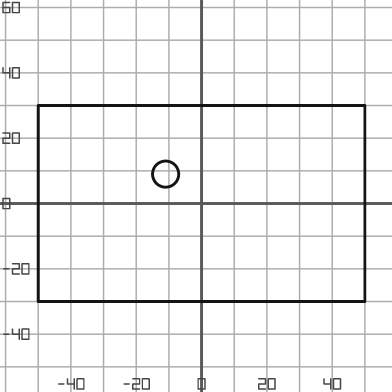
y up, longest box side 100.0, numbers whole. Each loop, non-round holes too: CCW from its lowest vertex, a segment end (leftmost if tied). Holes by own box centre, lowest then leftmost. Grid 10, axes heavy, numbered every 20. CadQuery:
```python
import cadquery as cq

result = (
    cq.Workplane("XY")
    .moveTo(-50.0, -30.0)
    .lineTo(50.0, -30.0)
    .lineTo(50.0, 30.0)
    .lineTo(-50.0, 30.0)
    .close()
    .moveTo(-11.0, 9.0)
    .circle(4.0)
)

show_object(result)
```